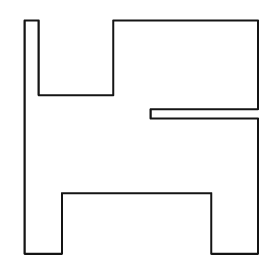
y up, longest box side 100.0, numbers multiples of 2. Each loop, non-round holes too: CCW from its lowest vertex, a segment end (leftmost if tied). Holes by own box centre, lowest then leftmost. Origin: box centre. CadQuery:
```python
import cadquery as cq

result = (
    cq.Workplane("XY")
    .moveTo(-50.0, -50.0)
    .lineTo(-34.0, -50.0)
    .lineTo(-34.0, -24.0)
    .lineTo(30.0, -24.0)
    .lineTo(30.0, -50.0)
    .lineTo(50.0, -50.0)
    .lineTo(50.0, 8.0)
    .lineTo(4.0, 8.0)
    .lineTo(4.0, 12.0)
    .lineTo(50.0, 12.0)
    .lineTo(50.0, 50.0)
    .lineTo(-12.0, 50.0)
    .lineTo(-12.0, 18.0)
    .lineTo(-44.0, 18.0)
    .lineTo(-44.0, 50.0)
    .lineTo(-50.0, 50.0)
    .close()
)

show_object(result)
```